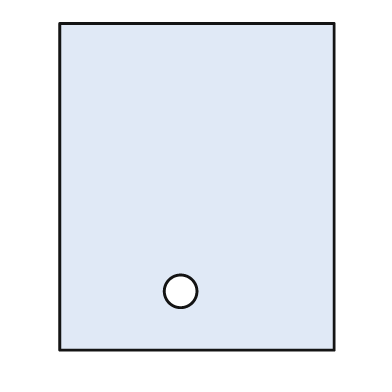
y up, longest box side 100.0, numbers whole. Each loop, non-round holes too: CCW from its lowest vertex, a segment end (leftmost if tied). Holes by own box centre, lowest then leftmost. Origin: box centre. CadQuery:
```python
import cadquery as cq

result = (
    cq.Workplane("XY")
    .moveTo(-42.0, -50.0)
    .lineTo(42.0, -50.0)
    .lineTo(42.0, 50.0)
    .lineTo(-42.0, 50.0)
    .close()
    .moveTo(-5.0, -32.0)
    .circle(5.0)
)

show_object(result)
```